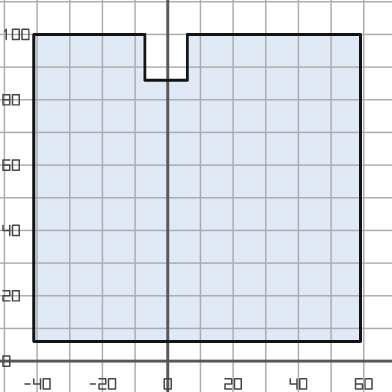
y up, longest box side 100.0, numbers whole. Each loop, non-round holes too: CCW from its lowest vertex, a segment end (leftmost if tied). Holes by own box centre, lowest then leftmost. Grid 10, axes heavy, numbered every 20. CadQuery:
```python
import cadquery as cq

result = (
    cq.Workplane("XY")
    .moveTo(-41.0, 6.0)
    .lineTo(59.0, 6.0)
    .lineTo(59.0, 100.0)
    .lineTo(6.0, 100.0)
    .lineTo(6.0, 86.0)
    .lineTo(-7.0, 86.0)
    .lineTo(-7.0, 100.0)
    .lineTo(-41.0, 100.0)
    .close()
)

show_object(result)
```